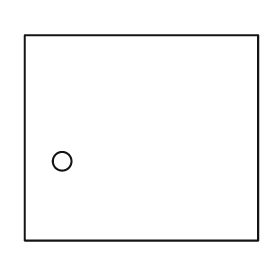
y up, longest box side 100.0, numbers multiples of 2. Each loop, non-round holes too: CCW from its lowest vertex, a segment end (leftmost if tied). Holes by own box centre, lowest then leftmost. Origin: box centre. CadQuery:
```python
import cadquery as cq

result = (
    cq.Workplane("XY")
    .moveTo(-50.0, -44.0)
    .lineTo(50.0, -44.0)
    .lineTo(50.0, 44.0)
    .lineTo(-50.0, 44.0)
    .close()
    .moveTo(-34.0, -10.0)
    .circle(4.0)
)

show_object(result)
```